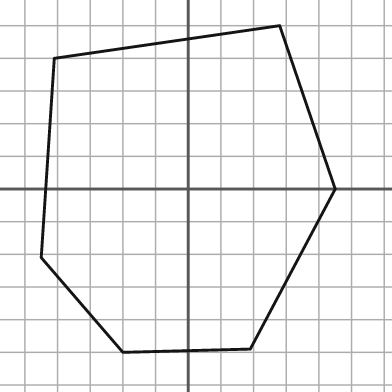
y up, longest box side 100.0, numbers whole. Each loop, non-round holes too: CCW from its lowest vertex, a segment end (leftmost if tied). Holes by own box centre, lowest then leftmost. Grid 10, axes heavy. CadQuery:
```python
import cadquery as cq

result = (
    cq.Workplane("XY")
    .moveTo(-20.0, -50.0)
    .lineTo(19.0, -49.0)
    .lineTo(45.0, 0.0)
    .lineTo(28.0, 50.0)
    .lineTo(-41.0, 40.0)
    .lineTo(-45.0, -21.0)
    .close()
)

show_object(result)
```